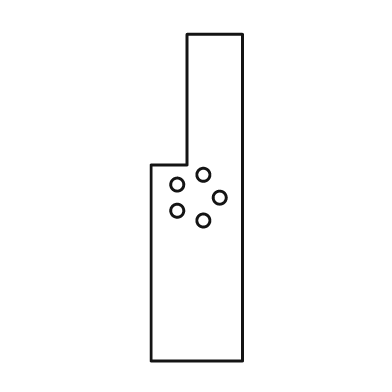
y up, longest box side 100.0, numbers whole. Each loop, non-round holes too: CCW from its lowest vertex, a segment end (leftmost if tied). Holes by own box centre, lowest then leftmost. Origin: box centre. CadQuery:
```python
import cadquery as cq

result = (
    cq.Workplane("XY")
    .moveTo(-14.0, -50.0)
    .lineTo(14.0, -50.0)
    .lineTo(14.0, 50.0)
    .lineTo(-3.0, 50.0)
    .lineTo(-3.0, 10.0)
    .lineTo(-14.0, 10.0)
    .close()
    .moveTo(2.0, -7.0)
    .circle(2.0)
    .moveTo(-6.0, -4.0)
    .circle(2.0)
    .moveTo(7.0, 0.0)
    .circle(2.0)
    .moveTo(-6.0, 4.0)
    .circle(2.0)
    .moveTo(2.0, 7.0)
    .circle(2.0)
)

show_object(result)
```